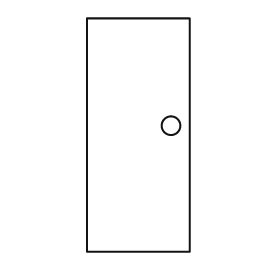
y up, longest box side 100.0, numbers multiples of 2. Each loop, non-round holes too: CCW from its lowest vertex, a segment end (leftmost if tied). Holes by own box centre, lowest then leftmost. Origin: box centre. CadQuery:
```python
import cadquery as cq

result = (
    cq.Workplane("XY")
    .moveTo(-22.0, -50.0)
    .lineTo(22.0, -50.0)
    .lineTo(22.0, 50.0)
    .lineTo(-22.0, 50.0)
    .close()
    .moveTo(14.0, 4.0)
    .circle(4.0)
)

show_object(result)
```